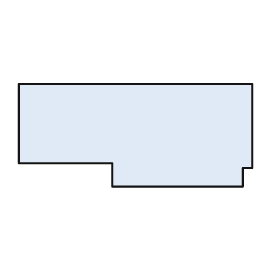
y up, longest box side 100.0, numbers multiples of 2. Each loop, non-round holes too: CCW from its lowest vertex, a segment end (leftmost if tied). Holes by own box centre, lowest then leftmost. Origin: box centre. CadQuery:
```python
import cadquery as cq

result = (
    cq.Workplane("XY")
    .moveTo(-10.0, -22.0)
    .lineTo(46.0, -22.0)
    .lineTo(46.0, -14.0)
    .lineTo(50.0, -14.0)
    .lineTo(50.0, 22.0)
    .lineTo(-50.0, 22.0)
    .lineTo(-50.0, -12.0)
    .lineTo(-10.0, -12.0)
    .close()
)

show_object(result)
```